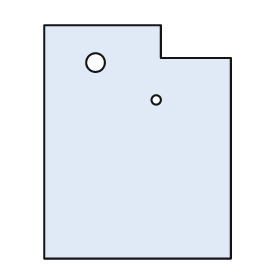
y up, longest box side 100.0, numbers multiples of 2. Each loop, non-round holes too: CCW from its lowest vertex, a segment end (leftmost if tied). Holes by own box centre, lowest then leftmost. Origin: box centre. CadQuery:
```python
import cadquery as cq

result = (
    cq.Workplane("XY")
    .moveTo(-40.0, -50.0)
    .lineTo(40.0, -50.0)
    .lineTo(40.0, 36.0)
    .lineTo(10.0, 36.0)
    .lineTo(10.0, 50.0)
    .lineTo(-40.0, 50.0)
    .close()
    .moveTo(8.0, 18.0)
    .circle(2.0)
    .moveTo(-18.0, 34.0)
    .circle(4.0)
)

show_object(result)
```